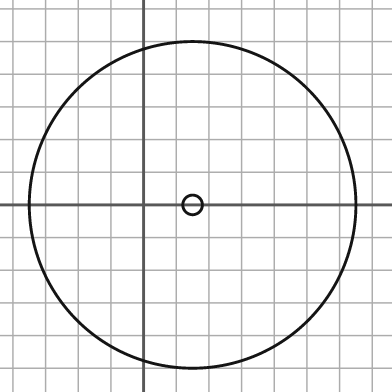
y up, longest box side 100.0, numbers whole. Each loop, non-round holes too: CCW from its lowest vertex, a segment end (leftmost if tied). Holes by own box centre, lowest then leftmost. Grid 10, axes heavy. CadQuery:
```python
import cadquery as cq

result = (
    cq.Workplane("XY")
    .moveTo(15.0, 0.0)
    .circle(50.0)
    .moveTo(15.0, 0.0)
    .circle(3.0)
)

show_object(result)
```